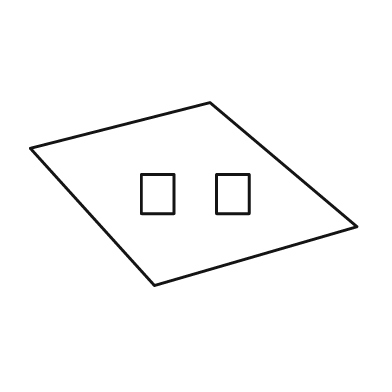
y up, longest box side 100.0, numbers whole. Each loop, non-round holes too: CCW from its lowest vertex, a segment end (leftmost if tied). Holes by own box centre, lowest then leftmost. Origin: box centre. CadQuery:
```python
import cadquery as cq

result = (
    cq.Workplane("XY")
    .moveTo(-12.0, -28.0)
    .lineTo(50.0, -10.0)
    .lineTo(5.0, 28.0)
    .lineTo(-50.0, 14.0)
    .close()
    .moveTo(-16.0, -6.0)
    .lineTo(-6.0, -6.0)
    .lineTo(-6.0, 6.0)
    .lineTo(-16.0, 6.0)
    .close()
    .moveTo(7.0, -6.0)
    .lineTo(17.0, -6.0)
    .lineTo(17.0, 6.0)
    .lineTo(7.0, 6.0)
    .close()
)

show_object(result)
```